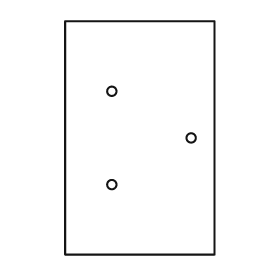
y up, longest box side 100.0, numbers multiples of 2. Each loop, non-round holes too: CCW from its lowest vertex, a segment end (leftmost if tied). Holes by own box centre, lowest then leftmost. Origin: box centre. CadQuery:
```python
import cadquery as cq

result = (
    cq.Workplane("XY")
    .moveTo(-32.0, -50.0)
    .lineTo(32.0, -50.0)
    .lineTo(32.0, 50.0)
    .lineTo(-32.0, 50.0)
    .close()
    .moveTo(-12.0, -20.0)
    .circle(2.0)
    .moveTo(22.0, 0.0)
    .circle(2.0)
    .moveTo(-12.0, 20.0)
    .circle(2.0)
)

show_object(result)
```